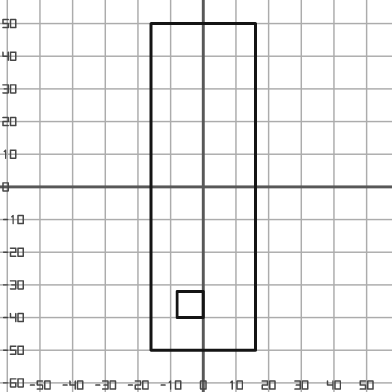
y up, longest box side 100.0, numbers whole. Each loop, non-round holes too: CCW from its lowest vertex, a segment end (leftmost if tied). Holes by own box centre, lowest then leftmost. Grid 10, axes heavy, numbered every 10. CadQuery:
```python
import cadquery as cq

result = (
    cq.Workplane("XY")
    .moveTo(-16.0, -50.0)
    .lineTo(16.0, -50.0)
    .lineTo(16.0, 50.0)
    .lineTo(-16.0, 50.0)
    .close()
    .moveTo(-8.0, -40.0)
    .lineTo(0.0, -40.0)
    .lineTo(0.0, -32.0)
    .lineTo(-8.0, -32.0)
    .close()
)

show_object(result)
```